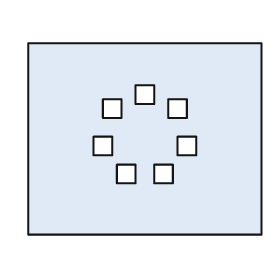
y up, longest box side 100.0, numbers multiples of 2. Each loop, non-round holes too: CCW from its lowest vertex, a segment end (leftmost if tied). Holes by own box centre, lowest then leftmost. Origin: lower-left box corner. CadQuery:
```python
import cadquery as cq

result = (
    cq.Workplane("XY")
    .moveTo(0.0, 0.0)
    .lineTo(100.0, 0.0)
    .lineTo(100.0, 82.0)
    .lineTo(0.0, 82.0)
    .close()
    .moveTo(38.0, 22.0)
    .lineTo(46.0, 22.0)
    .lineTo(46.0, 30.0)
    .lineTo(38.0, 30.0)
    .close()
    .moveTo(54.0, 22.0)
    .lineTo(62.0, 22.0)
    .lineTo(62.0, 30.0)
    .lineTo(54.0, 30.0)
    .close()
    .moveTo(28.0, 34.0)
    .lineTo(36.0, 34.0)
    .lineTo(36.0, 42.0)
    .lineTo(28.0, 42.0)
    .close()
    .moveTo(64.0, 34.0)
    .lineTo(72.0, 34.0)
    .lineTo(72.0, 42.0)
    .lineTo(64.0, 42.0)
    .close()
    .moveTo(32.0, 50.0)
    .lineTo(40.0, 50.0)
    .lineTo(40.0, 58.0)
    .lineTo(32.0, 58.0)
    .close()
    .moveTo(60.0, 50.0)
    .lineTo(68.0, 50.0)
    .lineTo(68.0, 58.0)
    .lineTo(60.0, 58.0)
    .close()
    .moveTo(46.0, 56.0)
    .lineTo(54.0, 56.0)
    .lineTo(54.0, 64.0)
    .lineTo(46.0, 64.0)
    .close()
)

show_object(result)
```